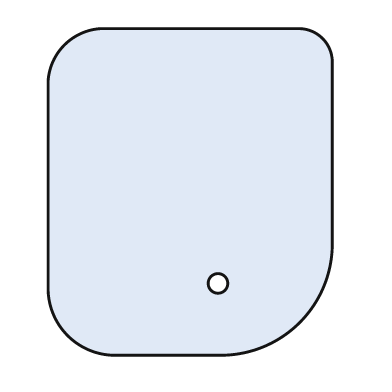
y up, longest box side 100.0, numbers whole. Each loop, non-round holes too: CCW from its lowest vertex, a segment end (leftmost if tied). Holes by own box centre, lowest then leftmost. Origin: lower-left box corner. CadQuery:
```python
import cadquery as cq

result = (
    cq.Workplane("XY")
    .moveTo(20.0, 0.0)
    .lineTo(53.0, 0.0)
    .threePointArc((77.0, 10.0), (87.0, 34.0))
    .lineTo(87.0, 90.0)
    .threePointArc((84.0, 97.0), (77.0, 100.0))
    .lineTo(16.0, 100.0)
    .threePointArc((5.0, 95.0), (0.0, 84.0))
    .lineTo(0.0, 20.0)
    .threePointArc((6.0, 6.0), (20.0, 0.0))
    .close()
    .moveTo(52.0, 22.0)
    .circle(3.0)
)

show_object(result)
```